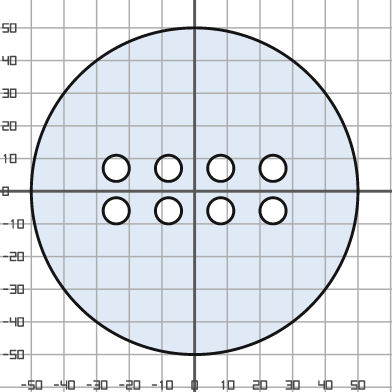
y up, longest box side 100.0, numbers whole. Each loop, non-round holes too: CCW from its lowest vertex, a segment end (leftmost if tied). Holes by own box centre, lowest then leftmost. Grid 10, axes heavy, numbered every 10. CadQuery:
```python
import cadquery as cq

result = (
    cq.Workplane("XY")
    .moveTo(0.0, 0.0)
    .circle(50.0)
    .moveTo(-24.0, -6.0)
    .circle(4.0)
    .moveTo(-8.0, -6.0)
    .circle(4.0)
    .moveTo(8.0, -6.0)
    .circle(4.0)
    .moveTo(24.0, -6.0)
    .circle(4.0)
    .moveTo(-24.0, 7.0)
    .circle(4.0)
    .moveTo(-8.0, 7.0)
    .circle(4.0)
    .moveTo(8.0, 7.0)
    .circle(4.0)
    .moveTo(24.0, 7.0)
    .circle(4.0)
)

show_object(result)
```